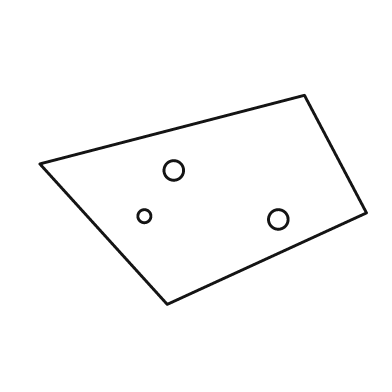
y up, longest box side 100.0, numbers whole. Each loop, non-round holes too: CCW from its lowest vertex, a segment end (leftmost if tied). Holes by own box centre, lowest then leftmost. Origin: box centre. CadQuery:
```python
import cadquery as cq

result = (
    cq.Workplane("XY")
    .moveTo(-11.0, -32.0)
    .lineTo(50.0, -4.0)
    .lineTo(31.0, 32.0)
    .lineTo(-50.0, 11.0)
    .close()
    .moveTo(23.0, -6.0)
    .circle(3.0)
    .moveTo(-18.0, -5.0)
    .circle(2.0)
    .moveTo(-9.0, 9.0)
    .circle(3.0)
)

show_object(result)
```